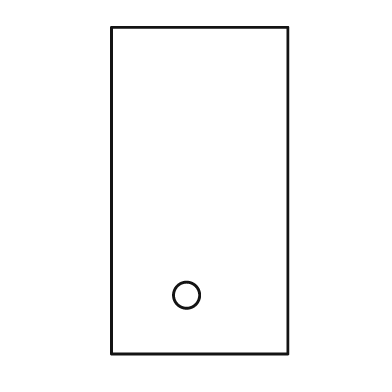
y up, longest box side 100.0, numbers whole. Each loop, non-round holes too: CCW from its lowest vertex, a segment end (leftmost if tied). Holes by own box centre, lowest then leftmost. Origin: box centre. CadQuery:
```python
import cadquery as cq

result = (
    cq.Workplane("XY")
    .moveTo(-27.0, -50.0)
    .lineTo(27.0, -50.0)
    .lineTo(27.0, 50.0)
    .lineTo(-27.0, 50.0)
    .close()
    .moveTo(-4.0, -32.0)
    .circle(4.0)
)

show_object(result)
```